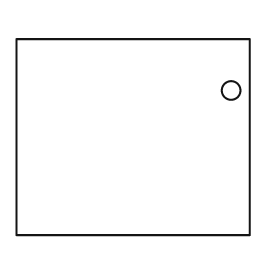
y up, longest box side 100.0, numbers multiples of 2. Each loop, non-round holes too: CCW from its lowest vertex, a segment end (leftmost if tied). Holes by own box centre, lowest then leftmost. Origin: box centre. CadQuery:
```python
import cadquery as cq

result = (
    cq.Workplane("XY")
    .moveTo(-50.0, -42.0)
    .lineTo(50.0, -42.0)
    .lineTo(50.0, 42.0)
    .lineTo(-50.0, 42.0)
    .close()
    .moveTo(42.0, 20.0)
    .circle(4.0)
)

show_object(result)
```